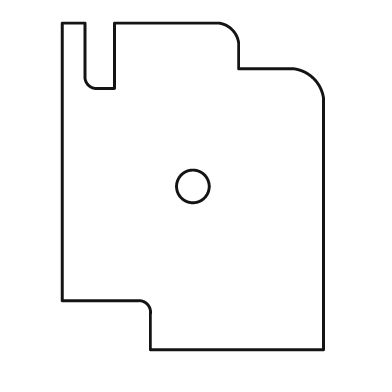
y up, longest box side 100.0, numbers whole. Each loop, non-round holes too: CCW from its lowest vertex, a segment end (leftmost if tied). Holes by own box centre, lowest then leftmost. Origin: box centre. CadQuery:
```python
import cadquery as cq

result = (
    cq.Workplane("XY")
    .moveTo(-13.0, -50.0)
    .lineTo(40.0, -50.0)
    .lineTo(40.0, 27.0)
    .threePointArc((37.0, 33.0), (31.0, 36.0))
    .lineTo(14.0, 36.0)
    .lineTo(14.0, 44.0)
    .threePointArc((12.0, 48.0), (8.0, 50.0))
    .lineTo(-24.0, 50.0)
    .lineTo(-24.0, 30.0)
    .lineTo(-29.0, 30.0)
    .threePointArc((-32.0, 31.0), (-33.0, 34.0))
    .lineTo(-33.0, 50.0)
    .lineTo(-40.0, 50.0)
    .lineTo(-40.0, -35.0)
    .lineTo(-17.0, -35.0)
    .threePointArc((-14.0, -36.0), (-13.0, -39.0))
    .close()
    .moveTo(0.0, 0.0)
    .circle(5.0)
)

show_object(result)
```